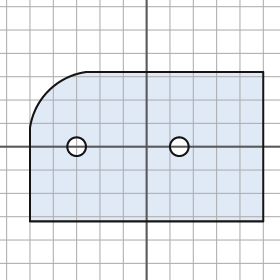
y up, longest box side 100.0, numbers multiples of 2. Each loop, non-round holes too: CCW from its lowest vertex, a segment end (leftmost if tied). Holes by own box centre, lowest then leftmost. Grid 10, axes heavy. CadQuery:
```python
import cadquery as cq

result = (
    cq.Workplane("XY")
    .moveTo(-50.0, -32.0)
    .lineTo(50.0, -32.0)
    .lineTo(50.0, 32.0)
    .lineTo(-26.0, 32.0)
    .threePointArc((-42.0, 24.0), (-50.0, 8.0))
    .close()
    .moveTo(-30.0, 0.0)
    .circle(4.0)
    .moveTo(14.0, 0.0)
    .circle(4.0)
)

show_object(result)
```